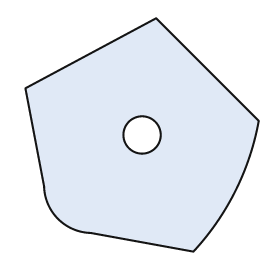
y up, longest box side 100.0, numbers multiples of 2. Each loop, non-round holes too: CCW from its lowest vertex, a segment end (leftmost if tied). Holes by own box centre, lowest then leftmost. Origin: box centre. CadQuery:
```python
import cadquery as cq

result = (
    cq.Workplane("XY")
    .moveTo(22.0, -50.0)
    .threePointArc((40.0, -24.0), (50.0, 6.0))
    .lineTo(6.0, 50.0)
    .lineTo(-50.0, 20.0)
    .lineTo(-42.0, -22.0)
    .threePointArc((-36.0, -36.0), (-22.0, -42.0))
    .close()
    .moveTo(0.0, 0.0)
    .circle(8.0)
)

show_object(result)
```